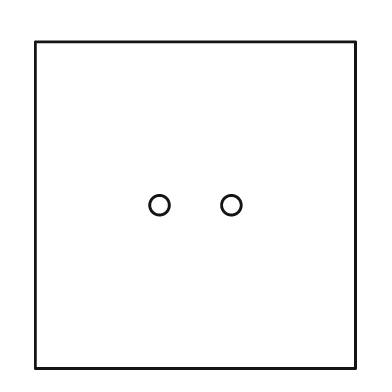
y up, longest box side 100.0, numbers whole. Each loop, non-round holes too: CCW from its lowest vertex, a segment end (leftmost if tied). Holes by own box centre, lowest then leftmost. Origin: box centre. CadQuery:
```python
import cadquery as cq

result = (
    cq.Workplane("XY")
    .moveTo(-49.0, -50.0)
    .lineTo(49.0, -50.0)
    .lineTo(49.0, 50.0)
    .lineTo(-49.0, 50.0)
    .close()
    .moveTo(-11.0, 0.0)
    .circle(3.0)
    .moveTo(11.0, 0.0)
    .circle(3.0)
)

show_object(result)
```